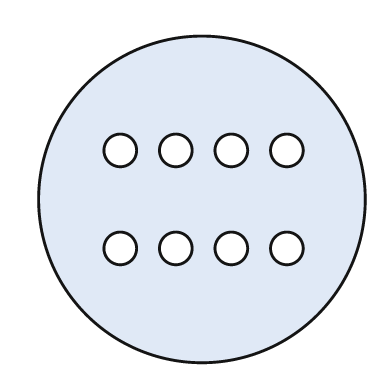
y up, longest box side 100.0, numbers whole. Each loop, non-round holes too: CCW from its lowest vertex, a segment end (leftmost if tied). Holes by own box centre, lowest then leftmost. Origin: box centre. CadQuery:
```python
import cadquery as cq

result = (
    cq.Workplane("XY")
    .moveTo(0.0, 0.0)
    .circle(50.0)
    .moveTo(-25.0, -15.0)
    .circle(5.0)
    .moveTo(-8.0, -15.0)
    .circle(5.0)
    .moveTo(9.0, -15.0)
    .circle(5.0)
    .moveTo(26.0, -15.0)
    .circle(5.0)
    .moveTo(-25.0, 15.0)
    .circle(5.0)
    .moveTo(-8.0, 15.0)
    .circle(5.0)
    .moveTo(9.0, 15.0)
    .circle(5.0)
    .moveTo(26.0, 15.0)
    .circle(5.0)
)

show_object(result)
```